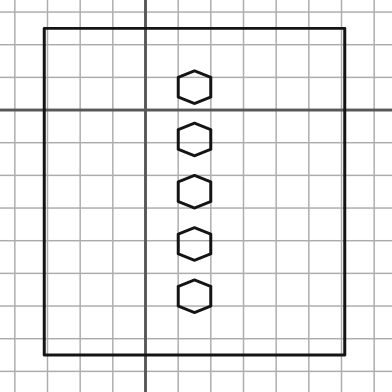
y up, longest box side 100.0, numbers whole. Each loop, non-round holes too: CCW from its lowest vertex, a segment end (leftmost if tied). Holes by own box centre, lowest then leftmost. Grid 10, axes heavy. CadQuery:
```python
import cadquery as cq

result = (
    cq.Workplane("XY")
    .moveTo(-31.0, -75.0)
    .lineTo(61.0, -75.0)
    .lineTo(61.0, 25.0)
    .lineTo(-31.0, 25.0)
    .close()
    .moveTo(15.0, -62.0)
    .lineTo(20.0, -60.0)
    .lineTo(20.0, -54.0)
    .lineTo(15.0, -52.0)
    .lineTo(10.0, -54.0)
    .lineTo(10.0, -60.0)
    .close()
    .moveTo(15.0, -46.0)
    .lineTo(20.0, -44.0)
    .lineTo(20.0, -38.0)
    .lineTo(15.0, -36.0)
    .lineTo(10.0, -38.0)
    .lineTo(10.0, -44.0)
    .close()
    .moveTo(15.0, -30.0)
    .lineTo(20.0, -28.0)
    .lineTo(20.0, -22.0)
    .lineTo(15.0, -20.0)
    .lineTo(10.0, -22.0)
    .lineTo(10.0, -28.0)
    .close()
    .moveTo(15.0, -14.0)
    .lineTo(20.0, -12.0)
    .lineTo(20.0, -6.0)
    .lineTo(15.0, -4.0)
    .lineTo(10.0, -6.0)
    .lineTo(10.0, -12.0)
    .close()
    .moveTo(15.0, 2.0)
    .lineTo(20.0, 4.0)
    .lineTo(20.0, 10.0)
    .lineTo(15.0, 12.0)
    .lineTo(10.0, 10.0)
    .lineTo(10.0, 4.0)
    .close()
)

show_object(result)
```